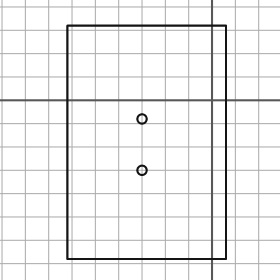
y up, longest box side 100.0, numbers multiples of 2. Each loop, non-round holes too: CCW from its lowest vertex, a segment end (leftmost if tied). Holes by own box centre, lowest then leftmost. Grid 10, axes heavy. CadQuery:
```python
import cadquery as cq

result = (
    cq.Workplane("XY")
    .moveTo(-62.0, -68.0)
    .lineTo(6.0, -68.0)
    .lineTo(6.0, 32.0)
    .lineTo(-62.0, 32.0)
    .close()
    .moveTo(-30.0, -30.0)
    .circle(2.0)
    .moveTo(-30.0, -8.0)
    .circle(2.0)
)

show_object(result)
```